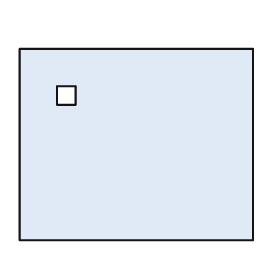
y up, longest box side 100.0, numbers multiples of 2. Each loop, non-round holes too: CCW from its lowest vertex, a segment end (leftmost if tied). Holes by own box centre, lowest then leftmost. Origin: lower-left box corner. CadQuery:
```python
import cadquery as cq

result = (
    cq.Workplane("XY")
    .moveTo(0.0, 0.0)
    .lineTo(100.0, 0.0)
    .lineTo(100.0, 82.0)
    .lineTo(0.0, 82.0)
    .close()
    .moveTo(16.0, 58.0)
    .lineTo(24.0, 58.0)
    .lineTo(24.0, 66.0)
    .lineTo(16.0, 66.0)
    .close()
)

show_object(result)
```